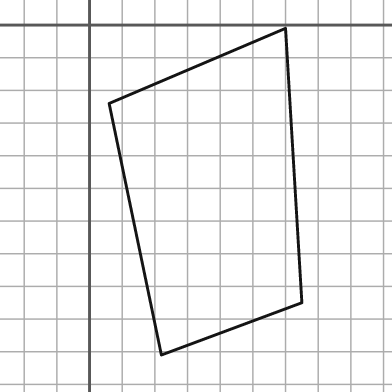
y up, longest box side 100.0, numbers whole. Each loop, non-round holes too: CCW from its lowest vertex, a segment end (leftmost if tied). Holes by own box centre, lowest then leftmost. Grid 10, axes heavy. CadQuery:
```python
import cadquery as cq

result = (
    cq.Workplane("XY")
    .moveTo(22.0, -101.0)
    .lineTo(65.0, -85.0)
    .lineTo(60.0, -1.0)
    .lineTo(6.0, -24.0)
    .close()
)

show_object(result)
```